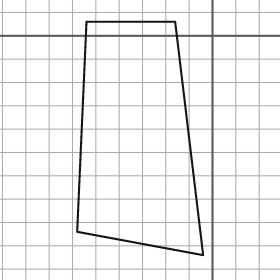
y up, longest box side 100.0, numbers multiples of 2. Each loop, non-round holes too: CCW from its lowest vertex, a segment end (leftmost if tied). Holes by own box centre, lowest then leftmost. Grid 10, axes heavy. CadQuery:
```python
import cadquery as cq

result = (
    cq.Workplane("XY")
    .moveTo(-4.0, -94.0)
    .lineTo(-16.0, 6.0)
    .lineTo(-54.0, 6.0)
    .lineTo(-58.0, -84.0)
    .close()
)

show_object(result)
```